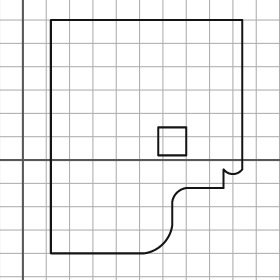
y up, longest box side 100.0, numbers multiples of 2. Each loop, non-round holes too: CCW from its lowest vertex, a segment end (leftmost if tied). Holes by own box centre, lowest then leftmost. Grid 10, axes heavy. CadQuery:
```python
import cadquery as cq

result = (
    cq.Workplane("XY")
    .moveTo(12.0, -40.0)
    .lineTo(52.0, -40.0)
    .threePointArc((60.0, -36.0), (64.0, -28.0))
    .lineTo(64.0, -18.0)
    .threePointArc((66.0, -14.0), (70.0, -12.0))
    .lineTo(86.0, -12.0)
    .lineTo(86.0, -4.0)
    .threePointArc((90.0, -6.0), (94.0, -4.0))
    .lineTo(94.0, 60.0)
    .lineTo(12.0, 60.0)
    .close()
    .moveTo(58.0, 2.0)
    .lineTo(70.0, 2.0)
    .lineTo(70.0, 14.0)
    .lineTo(58.0, 14.0)
    .close()
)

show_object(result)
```